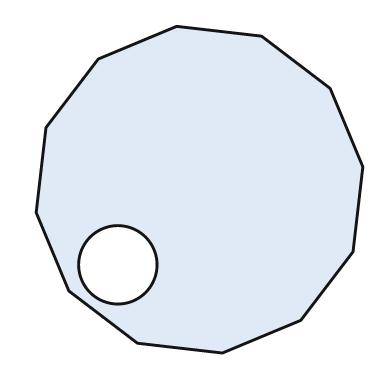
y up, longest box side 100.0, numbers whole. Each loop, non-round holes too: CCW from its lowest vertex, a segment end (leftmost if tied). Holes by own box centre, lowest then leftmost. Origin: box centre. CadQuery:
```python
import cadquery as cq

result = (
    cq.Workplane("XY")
    .moveTo(7.0, -50.0)
    .lineTo(31.0, -40.0)
    .lineTo(47.0, -19.0)
    .lineTo(50.0, 7.0)
    .lineTo(40.0, 31.0)
    .lineTo(19.0, 47.0)
    .lineTo(-7.0, 50.0)
    .lineTo(-31.0, 40.0)
    .lineTo(-47.0, 19.0)
    .lineTo(-50.0, -7.0)
    .lineTo(-40.0, -31.0)
    .lineTo(-19.0, -47.0)
    .close()
    .moveTo(-25.0, -23.0)
    .circle(12.0)
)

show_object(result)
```